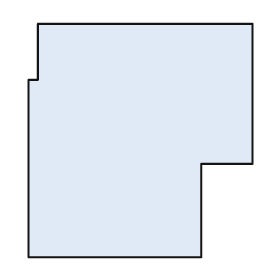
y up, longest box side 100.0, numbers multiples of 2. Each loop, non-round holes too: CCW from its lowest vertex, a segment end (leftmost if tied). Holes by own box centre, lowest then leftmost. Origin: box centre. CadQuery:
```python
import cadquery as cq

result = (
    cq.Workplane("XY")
    .moveTo(-48.0, -50.0)
    .lineTo(26.0, -50.0)
    .lineTo(26.0, -10.0)
    .lineTo(48.0, -10.0)
    .lineTo(48.0, 50.0)
    .lineTo(-44.0, 50.0)
    .lineTo(-44.0, 26.0)
    .lineTo(-48.0, 26.0)
    .close()
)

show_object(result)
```